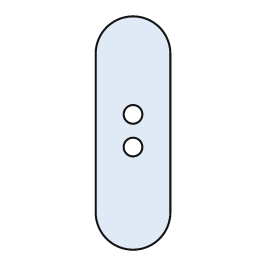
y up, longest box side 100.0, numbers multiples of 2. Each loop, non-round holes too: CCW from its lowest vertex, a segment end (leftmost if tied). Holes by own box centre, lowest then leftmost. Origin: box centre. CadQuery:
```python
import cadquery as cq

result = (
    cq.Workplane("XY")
    .moveTo(-16.0, -34.0)
    .threePointArc((0.0, -50.0), (16.0, -34.0))
    .lineTo(16.0, 34.0)
    .threePointArc((0.0, 50.0), (-16.0, 34.0))
    .close()
    .moveTo(0.0, -6.0)
    .circle(4.0)
    .moveTo(0.0, 8.0)
    .circle(4.0)
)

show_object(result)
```